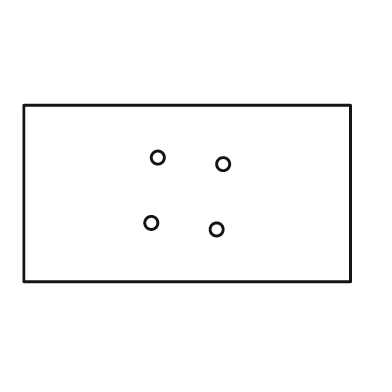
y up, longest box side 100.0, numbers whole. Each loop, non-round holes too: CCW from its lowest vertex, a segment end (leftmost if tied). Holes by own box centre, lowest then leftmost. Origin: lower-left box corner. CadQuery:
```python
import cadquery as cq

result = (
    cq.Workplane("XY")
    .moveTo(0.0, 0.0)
    .lineTo(100.0, 0.0)
    .lineTo(100.0, 54.0)
    .lineTo(0.0, 54.0)
    .close()
    .moveTo(59.0, 16.0)
    .circle(2.0)
    .moveTo(39.0, 18.0)
    .circle(2.0)
    .moveTo(61.0, 36.0)
    .circle(2.0)
    .moveTo(41.0, 38.0)
    .circle(2.0)
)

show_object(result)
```